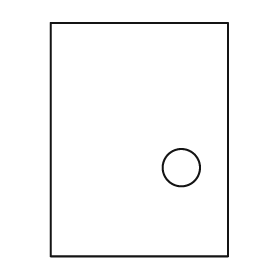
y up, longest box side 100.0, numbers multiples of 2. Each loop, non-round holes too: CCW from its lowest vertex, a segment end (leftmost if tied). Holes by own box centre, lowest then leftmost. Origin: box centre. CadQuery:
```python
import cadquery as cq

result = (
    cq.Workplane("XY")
    .moveTo(-38.0, -50.0)
    .lineTo(38.0, -50.0)
    .lineTo(38.0, 50.0)
    .lineTo(-38.0, 50.0)
    .close()
    .moveTo(18.0, -12.0)
    .circle(8.0)
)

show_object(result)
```